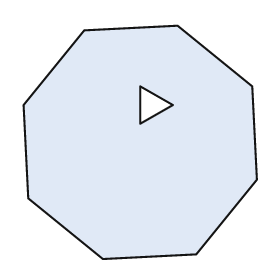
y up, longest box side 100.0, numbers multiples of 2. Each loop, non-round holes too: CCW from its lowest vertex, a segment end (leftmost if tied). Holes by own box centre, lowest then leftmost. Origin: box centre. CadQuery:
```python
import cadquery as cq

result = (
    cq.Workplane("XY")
    .moveTo(-16.0, -50.0)
    .lineTo(24.0, -48.0)
    .lineTo(50.0, -16.0)
    .lineTo(48.0, 24.0)
    .lineTo(16.0, 50.0)
    .lineTo(-24.0, 48.0)
    .lineTo(-50.0, 16.0)
    .lineTo(-48.0, -24.0)
    .close()
    .moveTo(0.0, 8.0)
    .lineTo(14.0, 16.0)
    .lineTo(0.0, 24.0)
    .close()
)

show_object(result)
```